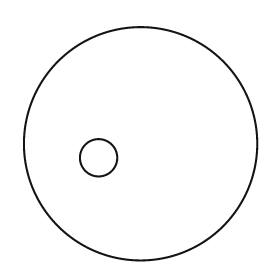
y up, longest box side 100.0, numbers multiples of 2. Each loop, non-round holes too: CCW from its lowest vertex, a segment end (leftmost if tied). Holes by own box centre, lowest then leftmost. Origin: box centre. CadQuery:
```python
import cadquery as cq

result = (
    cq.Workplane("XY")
    .moveTo(0.0, 0.0)
    .circle(50.0)
    .moveTo(-18.0, -6.0)
    .circle(8.0)
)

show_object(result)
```